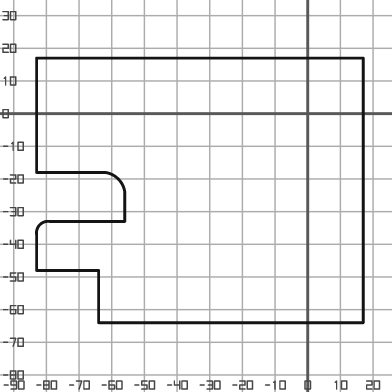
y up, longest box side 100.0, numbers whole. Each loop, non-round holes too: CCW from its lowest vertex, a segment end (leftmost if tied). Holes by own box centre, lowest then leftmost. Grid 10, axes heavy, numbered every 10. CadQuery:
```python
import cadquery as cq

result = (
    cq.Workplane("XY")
    .moveTo(-64.0, -64.0)
    .lineTo(17.0, -64.0)
    .lineTo(17.0, 17.0)
    .lineTo(-83.0, 17.0)
    .lineTo(-83.0, -18.0)
    .lineTo(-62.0, -18.0)
    .threePointArc((-58.0, -20.0), (-56.0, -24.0))
    .lineTo(-56.0, -33.0)
    .lineTo(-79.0, -33.0)
    .threePointArc((-82.0, -34.0), (-83.0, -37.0))
    .lineTo(-83.0, -48.0)
    .lineTo(-64.0, -48.0)
    .close()
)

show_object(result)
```